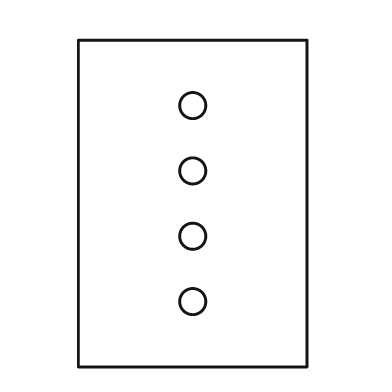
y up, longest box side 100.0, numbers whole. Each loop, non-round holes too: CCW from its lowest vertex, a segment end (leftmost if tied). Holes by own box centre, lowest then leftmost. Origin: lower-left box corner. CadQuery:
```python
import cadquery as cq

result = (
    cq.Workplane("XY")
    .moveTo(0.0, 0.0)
    .lineTo(70.0, 0.0)
    .lineTo(70.0, 100.0)
    .lineTo(0.0, 100.0)
    .close()
    .moveTo(35.0, 20.0)
    .circle(4.0)
    .moveTo(35.0, 40.0)
    .circle(4.0)
    .moveTo(35.0, 60.0)
    .circle(4.0)
    .moveTo(35.0, 80.0)
    .circle(4.0)
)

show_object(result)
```